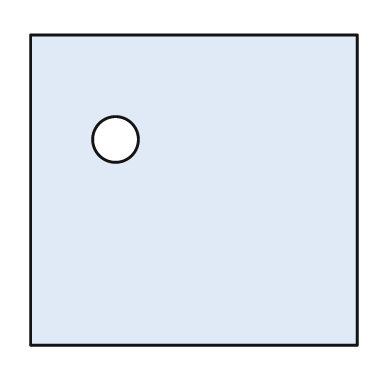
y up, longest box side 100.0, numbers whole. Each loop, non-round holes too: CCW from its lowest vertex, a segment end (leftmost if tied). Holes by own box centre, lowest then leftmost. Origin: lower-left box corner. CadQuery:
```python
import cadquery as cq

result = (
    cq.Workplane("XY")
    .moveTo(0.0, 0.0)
    .lineTo(100.0, 0.0)
    .lineTo(100.0, 95.0)
    .lineTo(0.0, 95.0)
    .close()
    .moveTo(26.0, 63.0)
    .circle(7.0)
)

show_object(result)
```